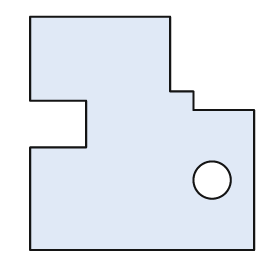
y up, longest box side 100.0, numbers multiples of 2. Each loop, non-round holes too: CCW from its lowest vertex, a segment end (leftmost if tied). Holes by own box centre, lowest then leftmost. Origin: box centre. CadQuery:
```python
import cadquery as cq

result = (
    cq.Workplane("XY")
    .moveTo(-48.0, -50.0)
    .lineTo(48.0, -50.0)
    .lineTo(48.0, 10.0)
    .lineTo(22.0, 10.0)
    .lineTo(22.0, 18.0)
    .lineTo(12.0, 18.0)
    .lineTo(12.0, 50.0)
    .lineTo(-48.0, 50.0)
    .lineTo(-48.0, 14.0)
    .lineTo(-24.0, 14.0)
    .lineTo(-24.0, -6.0)
    .lineTo(-48.0, -6.0)
    .close()
    .moveTo(30.0, -20.0)
    .circle(8.0)
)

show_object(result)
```